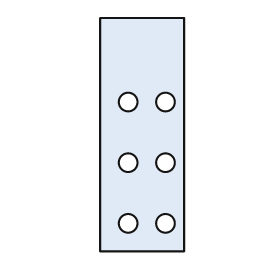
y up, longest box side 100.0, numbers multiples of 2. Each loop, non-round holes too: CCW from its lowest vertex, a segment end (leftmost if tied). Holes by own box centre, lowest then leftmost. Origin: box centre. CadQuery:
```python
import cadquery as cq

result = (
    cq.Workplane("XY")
    .moveTo(-18.0, -50.0)
    .lineTo(18.0, -50.0)
    .lineTo(18.0, 50.0)
    .lineTo(-18.0, 50.0)
    .close()
    .moveTo(-6.0, -38.0)
    .circle(4.0)
    .moveTo(10.0, -38.0)
    .circle(4.0)
    .moveTo(-6.0, -12.0)
    .circle(4.0)
    .moveTo(10.0, -12.0)
    .circle(4.0)
    .moveTo(-6.0, 14.0)
    .circle(4.0)
    .moveTo(10.0, 14.0)
    .circle(4.0)
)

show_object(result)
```